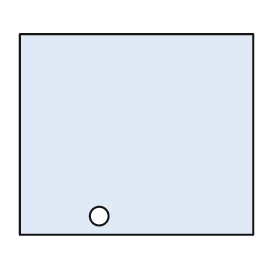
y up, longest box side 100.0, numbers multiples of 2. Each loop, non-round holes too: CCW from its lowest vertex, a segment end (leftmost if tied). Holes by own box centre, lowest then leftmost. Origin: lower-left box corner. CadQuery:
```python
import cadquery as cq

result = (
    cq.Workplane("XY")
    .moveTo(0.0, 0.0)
    .lineTo(100.0, 0.0)
    .lineTo(100.0, 86.0)
    .lineTo(0.0, 86.0)
    .close()
    .moveTo(34.0, 8.0)
    .circle(4.0)
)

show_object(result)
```